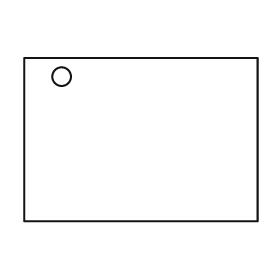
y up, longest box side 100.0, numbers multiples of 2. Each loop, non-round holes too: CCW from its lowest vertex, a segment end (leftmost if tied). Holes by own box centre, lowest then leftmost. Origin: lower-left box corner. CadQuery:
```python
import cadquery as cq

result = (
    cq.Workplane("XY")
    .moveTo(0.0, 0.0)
    .lineTo(100.0, 0.0)
    .lineTo(100.0, 70.0)
    .lineTo(0.0, 70.0)
    .close()
    .moveTo(16.0, 62.0)
    .circle(4.0)
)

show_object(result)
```